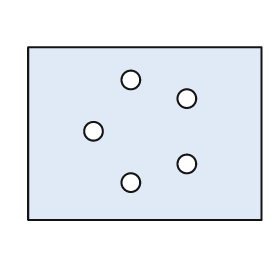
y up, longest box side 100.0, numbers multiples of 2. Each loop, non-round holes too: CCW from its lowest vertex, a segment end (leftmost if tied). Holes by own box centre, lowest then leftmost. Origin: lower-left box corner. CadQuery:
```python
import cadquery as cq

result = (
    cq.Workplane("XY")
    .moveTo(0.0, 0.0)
    .lineTo(100.0, 0.0)
    .lineTo(100.0, 74.0)
    .lineTo(0.0, 74.0)
    .close()
    .moveTo(44.0, 16.0)
    .circle(4.0)
    .moveTo(68.0, 24.0)
    .circle(4.0)
    .moveTo(28.0, 38.0)
    .circle(4.0)
    .moveTo(68.0, 52.0)
    .circle(4.0)
    .moveTo(44.0, 60.0)
    .circle(4.0)
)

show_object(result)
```